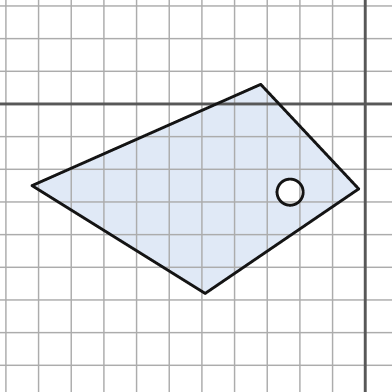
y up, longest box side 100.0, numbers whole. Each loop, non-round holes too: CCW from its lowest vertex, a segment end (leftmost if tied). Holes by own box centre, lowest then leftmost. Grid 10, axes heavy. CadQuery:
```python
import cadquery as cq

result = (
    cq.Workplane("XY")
    .moveTo(-49.0, -58.0)
    .lineTo(-2.0, -26.0)
    .lineTo(-32.0, 6.0)
    .lineTo(-102.0, -25.0)
    .close()
    .moveTo(-23.0, -27.0)
    .circle(4.0)
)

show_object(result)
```